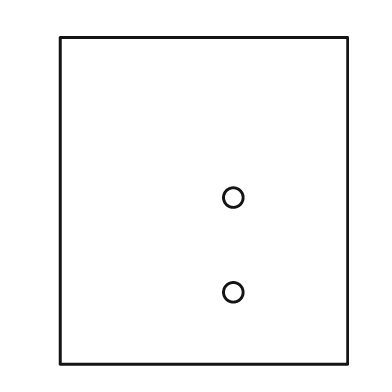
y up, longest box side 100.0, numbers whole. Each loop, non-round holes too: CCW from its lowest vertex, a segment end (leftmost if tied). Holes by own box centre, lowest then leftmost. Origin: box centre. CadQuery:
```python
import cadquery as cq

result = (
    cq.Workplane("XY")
    .moveTo(-44.0, -50.0)
    .lineTo(44.0, -50.0)
    .lineTo(44.0, 50.0)
    .lineTo(-44.0, 50.0)
    .close()
    .moveTo(9.0, -28.0)
    .circle(3.0)
    .moveTo(9.0, 1.0)
    .circle(3.0)
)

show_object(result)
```